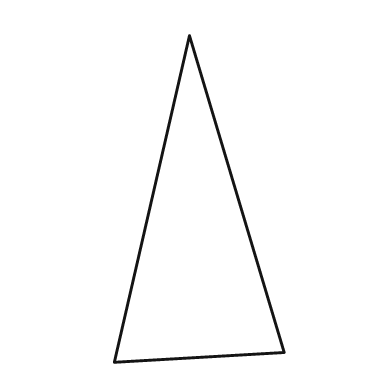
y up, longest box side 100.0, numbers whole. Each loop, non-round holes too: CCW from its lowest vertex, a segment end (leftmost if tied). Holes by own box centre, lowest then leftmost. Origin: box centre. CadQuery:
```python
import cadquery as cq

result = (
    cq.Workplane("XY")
    .moveTo(-26.0, -50.0)
    .lineTo(26.0, -47.0)
    .lineTo(-3.0, 50.0)
    .close()
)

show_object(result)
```